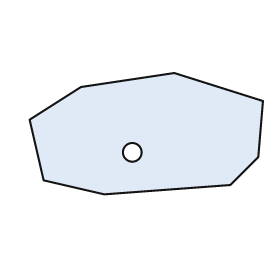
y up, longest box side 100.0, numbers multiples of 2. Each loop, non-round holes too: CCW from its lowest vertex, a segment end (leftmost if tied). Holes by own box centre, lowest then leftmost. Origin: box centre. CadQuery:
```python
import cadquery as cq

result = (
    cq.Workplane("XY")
    .moveTo(-18.0, -26.0)
    .lineTo(36.0, -22.0)
    .lineTo(48.0, -10.0)
    .lineTo(50.0, 14.0)
    .lineTo(12.0, 26.0)
    .lineTo(-28.0, 20.0)
    .lineTo(-50.0, 6.0)
    .lineTo(-44.0, -20.0)
    .close()
    .moveTo(-6.0, -8.0)
    .circle(4.0)
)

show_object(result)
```